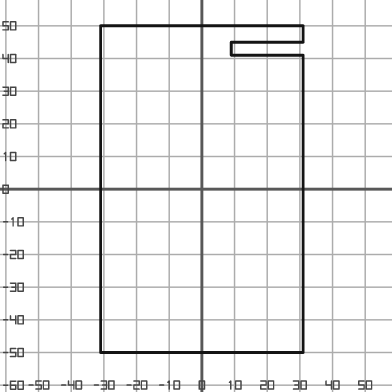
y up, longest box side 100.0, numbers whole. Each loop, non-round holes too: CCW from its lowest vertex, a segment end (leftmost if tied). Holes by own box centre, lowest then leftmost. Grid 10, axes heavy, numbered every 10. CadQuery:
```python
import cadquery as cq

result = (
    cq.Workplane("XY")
    .moveTo(-31.0, -50.0)
    .lineTo(31.0, -50.0)
    .lineTo(31.0, 41.0)
    .lineTo(9.0, 41.0)
    .lineTo(9.0, 45.0)
    .lineTo(31.0, 45.0)
    .lineTo(31.0, 50.0)
    .lineTo(-31.0, 50.0)
    .close()
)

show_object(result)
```